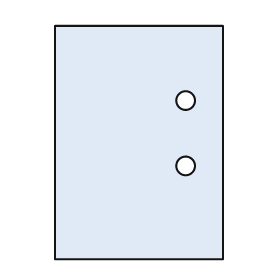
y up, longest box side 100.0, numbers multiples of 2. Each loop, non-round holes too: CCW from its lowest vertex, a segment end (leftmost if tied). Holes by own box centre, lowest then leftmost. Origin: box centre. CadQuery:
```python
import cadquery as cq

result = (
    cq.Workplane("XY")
    .moveTo(-36.0, -50.0)
    .lineTo(36.0, -50.0)
    .lineTo(36.0, 50.0)
    .lineTo(-36.0, 50.0)
    .close()
    .moveTo(20.0, -10.0)
    .circle(4.0)
    .moveTo(20.0, 18.0)
    .circle(4.0)
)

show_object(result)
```